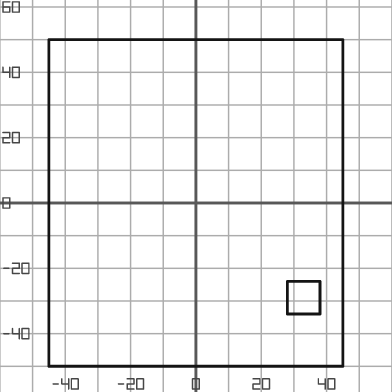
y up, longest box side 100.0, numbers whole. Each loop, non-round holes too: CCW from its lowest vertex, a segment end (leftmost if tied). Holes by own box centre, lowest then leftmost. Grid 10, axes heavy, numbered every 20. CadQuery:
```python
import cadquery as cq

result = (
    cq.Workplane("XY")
    .moveTo(-45.0, -50.0)
    .lineTo(45.0, -50.0)
    .lineTo(45.0, 50.0)
    .lineTo(-45.0, 50.0)
    .close()
    .moveTo(28.0, -34.0)
    .lineTo(38.0, -34.0)
    .lineTo(38.0, -24.0)
    .lineTo(28.0, -24.0)
    .close()
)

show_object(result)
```